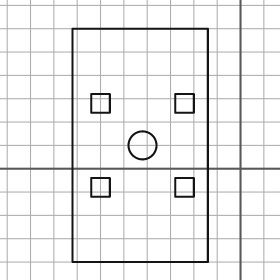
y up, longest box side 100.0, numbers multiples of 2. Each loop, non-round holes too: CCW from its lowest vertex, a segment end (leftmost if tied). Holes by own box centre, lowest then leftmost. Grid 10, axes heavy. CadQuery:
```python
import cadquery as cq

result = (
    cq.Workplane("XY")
    .moveTo(-72.0, -40.0)
    .lineTo(-14.0, -40.0)
    .lineTo(-14.0, 60.0)
    .lineTo(-72.0, 60.0)
    .close()
    .moveTo(-64.0, -12.0)
    .lineTo(-56.0, -12.0)
    .lineTo(-56.0, -4.0)
    .lineTo(-64.0, -4.0)
    .close()
    .moveTo(-28.0, -12.0)
    .lineTo(-20.0, -12.0)
    .lineTo(-20.0, -4.0)
    .lineTo(-28.0, -4.0)
    .close()
    .moveTo(-42.0, 10.0)
    .circle(6.0)
    .moveTo(-64.0, 24.0)
    .lineTo(-56.0, 24.0)
    .lineTo(-56.0, 32.0)
    .lineTo(-64.0, 32.0)
    .close()
    .moveTo(-28.0, 24.0)
    .lineTo(-20.0, 24.0)
    .lineTo(-20.0, 32.0)
    .lineTo(-28.0, 32.0)
    .close()
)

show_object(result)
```